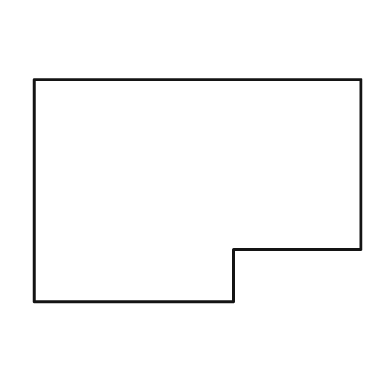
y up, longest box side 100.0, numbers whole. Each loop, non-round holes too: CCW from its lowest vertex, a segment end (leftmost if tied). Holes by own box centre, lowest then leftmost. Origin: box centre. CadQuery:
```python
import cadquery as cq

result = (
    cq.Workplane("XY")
    .moveTo(-50.0, -34.0)
    .lineTo(11.0, -34.0)
    .lineTo(11.0, -18.0)
    .lineTo(50.0, -18.0)
    .lineTo(50.0, 34.0)
    .lineTo(-50.0, 34.0)
    .close()
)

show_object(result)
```